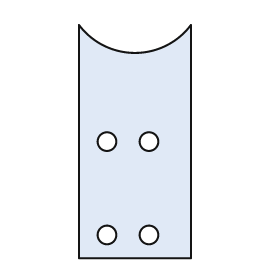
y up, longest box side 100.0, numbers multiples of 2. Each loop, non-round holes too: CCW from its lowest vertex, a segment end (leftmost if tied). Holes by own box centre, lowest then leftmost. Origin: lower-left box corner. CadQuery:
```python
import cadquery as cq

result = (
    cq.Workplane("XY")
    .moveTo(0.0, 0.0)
    .lineTo(48.0, 0.0)
    .lineTo(48.0, 100.0)
    .threePointArc((24.0, 88.0), (0.0, 100.0))
    .close()
    .moveTo(12.0, 10.0)
    .circle(4.0)
    .moveTo(30.0, 10.0)
    .circle(4.0)
    .moveTo(12.0, 50.0)
    .circle(4.0)
    .moveTo(30.0, 50.0)
    .circle(4.0)
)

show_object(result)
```